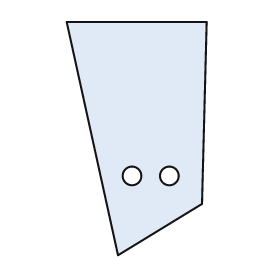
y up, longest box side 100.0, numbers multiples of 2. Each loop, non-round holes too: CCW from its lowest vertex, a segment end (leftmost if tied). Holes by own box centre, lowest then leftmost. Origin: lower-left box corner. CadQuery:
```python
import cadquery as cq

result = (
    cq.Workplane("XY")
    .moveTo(22.0, 0.0)
    .lineTo(58.0, 22.0)
    .lineTo(60.0, 100.0)
    .lineTo(0.0, 100.0)
    .close()
    .moveTo(28.0, 34.0)
    .circle(4.0)
    .moveTo(44.0, 34.0)
    .circle(4.0)
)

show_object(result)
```